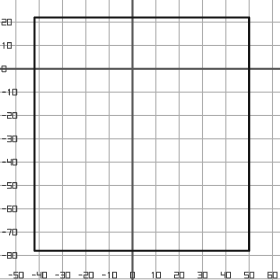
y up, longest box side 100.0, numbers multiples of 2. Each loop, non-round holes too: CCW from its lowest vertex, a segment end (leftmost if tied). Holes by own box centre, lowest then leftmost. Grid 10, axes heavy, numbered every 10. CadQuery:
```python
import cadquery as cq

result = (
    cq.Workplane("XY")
    .moveTo(-42.0, -78.0)
    .lineTo(50.0, -78.0)
    .lineTo(50.0, 22.0)
    .lineTo(-42.0, 22.0)
    .close()
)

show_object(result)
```